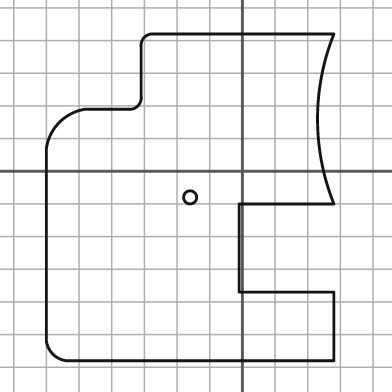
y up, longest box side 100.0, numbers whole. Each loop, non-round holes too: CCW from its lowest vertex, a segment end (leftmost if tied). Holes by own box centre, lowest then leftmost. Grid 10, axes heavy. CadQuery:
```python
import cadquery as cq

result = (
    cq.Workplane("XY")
    .moveTo(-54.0, -58.0)
    .lineTo(28.0, -58.0)
    .lineTo(28.0, -37.0)
    .lineTo(-1.0, -37.0)
    .lineTo(-1.0, -10.0)
    .lineTo(28.0, -10.0)
    .threePointArc((23.0, 16.0), (28.0, 42.0))
    .lineTo(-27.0, 42.0)
    .threePointArc((-30.0, 41.0), (-31.0, 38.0))
    .lineTo(-31.0, 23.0)
    .threePointArc((-32.0, 20.0), (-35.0, 19.0))
    .lineTo(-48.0, 19.0)
    .threePointArc((-56.0, 15.0), (-60.0, 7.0))
    .lineTo(-60.0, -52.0)
    .threePointArc((-58.0, -56.0), (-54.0, -58.0))
    .close()
    .moveTo(-16.0, -8.0)
    .circle(2.0)
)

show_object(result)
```